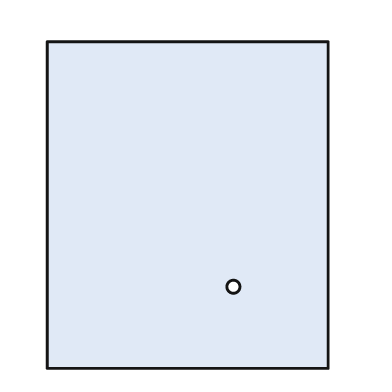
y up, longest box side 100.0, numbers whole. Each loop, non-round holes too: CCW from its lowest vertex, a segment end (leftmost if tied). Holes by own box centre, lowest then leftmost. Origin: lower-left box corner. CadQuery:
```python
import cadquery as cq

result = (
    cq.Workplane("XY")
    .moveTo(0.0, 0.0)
    .lineTo(86.0, 0.0)
    .lineTo(86.0, 100.0)
    .lineTo(0.0, 100.0)
    .close()
    .moveTo(57.0, 25.0)
    .circle(2.0)
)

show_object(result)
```